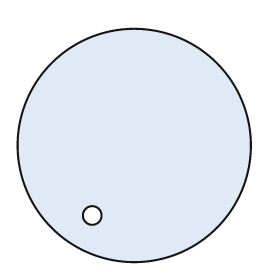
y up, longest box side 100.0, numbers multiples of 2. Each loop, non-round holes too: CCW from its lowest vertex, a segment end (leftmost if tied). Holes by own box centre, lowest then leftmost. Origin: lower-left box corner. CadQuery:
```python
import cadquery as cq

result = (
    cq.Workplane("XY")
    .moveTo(50.0, 50.0)
    .circle(50.0)
    .moveTo(32.0, 20.0)
    .circle(4.0)
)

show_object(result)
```